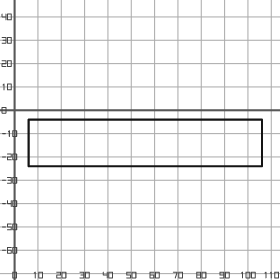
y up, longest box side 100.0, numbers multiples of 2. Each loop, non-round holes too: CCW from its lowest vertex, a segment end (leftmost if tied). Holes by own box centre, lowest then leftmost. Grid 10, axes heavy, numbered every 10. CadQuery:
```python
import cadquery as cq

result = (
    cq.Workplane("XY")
    .moveTo(6.0, -24.0)
    .lineTo(106.0, -24.0)
    .lineTo(106.0, -4.0)
    .lineTo(6.0, -4.0)
    .close()
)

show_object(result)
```